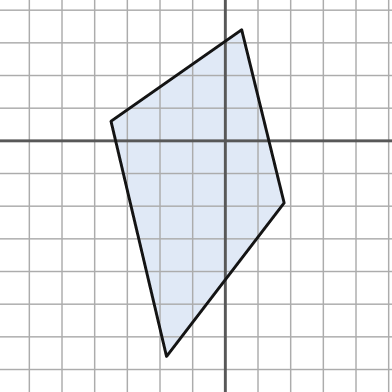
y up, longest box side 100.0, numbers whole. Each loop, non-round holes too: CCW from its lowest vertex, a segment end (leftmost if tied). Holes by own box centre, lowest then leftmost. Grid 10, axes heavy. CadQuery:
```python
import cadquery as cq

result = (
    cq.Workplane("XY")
    .moveTo(-18.0, -66.0)
    .lineTo(18.0, -19.0)
    .lineTo(5.0, 34.0)
    .lineTo(-35.0, 6.0)
    .close()
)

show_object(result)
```